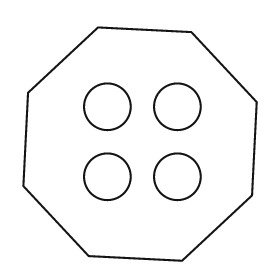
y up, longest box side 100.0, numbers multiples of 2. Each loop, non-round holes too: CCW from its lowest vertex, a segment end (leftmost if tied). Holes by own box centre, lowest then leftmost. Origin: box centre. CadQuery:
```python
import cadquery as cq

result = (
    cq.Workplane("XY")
    .moveTo(18.0, -50.0)
    .lineTo(48.0, -22.0)
    .lineTo(50.0, 18.0)
    .lineTo(22.0, 48.0)
    .lineTo(-18.0, 50.0)
    .lineTo(-48.0, 22.0)
    .lineTo(-50.0, -18.0)
    .lineTo(-22.0, -48.0)
    .close()
    .moveTo(-14.0, -14.0)
    .circle(10.0)
    .moveTo(16.0, -14.0)
    .circle(10.0)
    .moveTo(-14.0, 16.0)
    .circle(10.0)
    .moveTo(16.0, 16.0)
    .circle(10.0)
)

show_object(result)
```